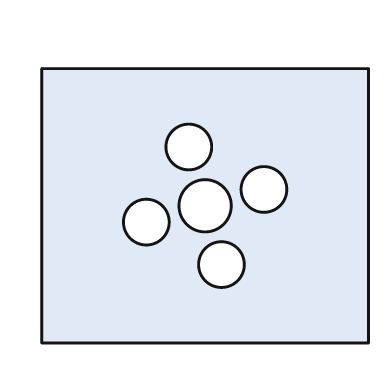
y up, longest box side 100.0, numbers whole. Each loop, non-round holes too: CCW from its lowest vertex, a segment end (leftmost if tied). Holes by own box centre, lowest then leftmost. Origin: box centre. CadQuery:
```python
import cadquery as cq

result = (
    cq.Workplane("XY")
    .moveTo(-50.0, -42.0)
    .lineTo(50.0, -42.0)
    .lineTo(50.0, 42.0)
    .lineTo(-50.0, 42.0)
    .close()
    .moveTo(5.0, -18.0)
    .circle(7.0)
    .moveTo(-18.0, -5.0)
    .circle(7.0)
    .moveTo(0.0, 0.0)
    .circle(8.0)
    .moveTo(18.0, 5.0)
    .circle(7.0)
    .moveTo(-5.0, 18.0)
    .circle(7.0)
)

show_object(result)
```